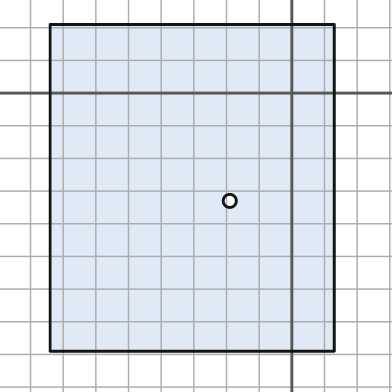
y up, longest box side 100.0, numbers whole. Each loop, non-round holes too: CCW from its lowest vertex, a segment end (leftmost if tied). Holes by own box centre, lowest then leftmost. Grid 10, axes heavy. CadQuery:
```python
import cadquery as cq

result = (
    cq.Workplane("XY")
    .moveTo(-74.0, -79.0)
    .lineTo(13.0, -79.0)
    .lineTo(13.0, 21.0)
    .lineTo(-74.0, 21.0)
    .close()
    .moveTo(-19.0, -33.0)
    .circle(2.0)
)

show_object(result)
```